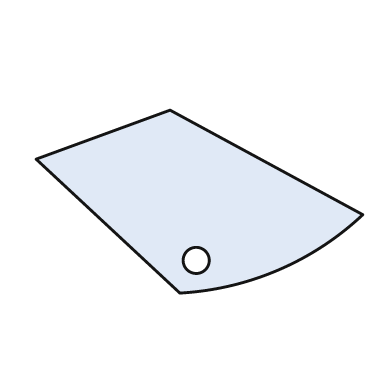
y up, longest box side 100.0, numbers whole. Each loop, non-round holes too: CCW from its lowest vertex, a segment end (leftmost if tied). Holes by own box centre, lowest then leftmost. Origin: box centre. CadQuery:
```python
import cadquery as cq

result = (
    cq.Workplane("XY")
    .moveTo(-6.0, -28.0)
    .threePointArc((24.0, -21.0), (50.0, -4.0))
    .lineTo(-9.0, 28.0)
    .lineTo(-50.0, 13.0)
    .close()
    .moveTo(-1.0, -18.0)
    .circle(4.0)
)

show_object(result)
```